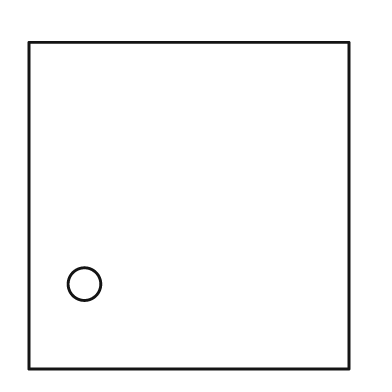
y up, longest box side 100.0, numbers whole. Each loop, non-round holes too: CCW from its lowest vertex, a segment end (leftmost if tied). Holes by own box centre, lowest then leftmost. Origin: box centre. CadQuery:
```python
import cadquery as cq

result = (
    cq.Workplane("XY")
    .moveTo(-49.0, -50.0)
    .lineTo(49.0, -50.0)
    .lineTo(49.0, 50.0)
    .lineTo(-49.0, 50.0)
    .close()
    .moveTo(-32.0, -24.0)
    .circle(5.0)
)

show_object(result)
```